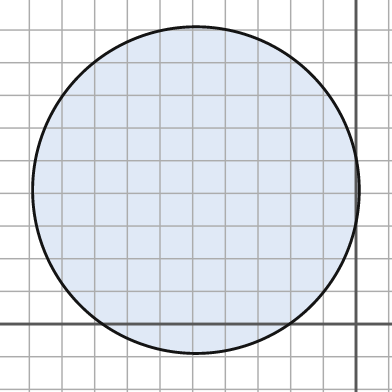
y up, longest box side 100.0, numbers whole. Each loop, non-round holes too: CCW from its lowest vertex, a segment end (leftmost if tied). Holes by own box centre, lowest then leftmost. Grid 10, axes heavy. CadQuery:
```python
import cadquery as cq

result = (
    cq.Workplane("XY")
    .moveTo(-49.0, 41.0)
    .circle(50.0)
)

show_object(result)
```